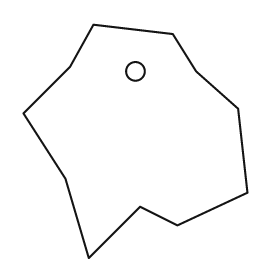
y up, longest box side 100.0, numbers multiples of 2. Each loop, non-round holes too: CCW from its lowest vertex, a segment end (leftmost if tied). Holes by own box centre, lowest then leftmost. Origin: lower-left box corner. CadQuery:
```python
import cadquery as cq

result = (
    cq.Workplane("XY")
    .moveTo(28.0, 0.0)
    .lineTo(50.0, 22.0)
    .lineTo(66.0, 14.0)
    .lineTo(96.0, 28.0)
    .lineTo(92.0, 64.0)
    .lineTo(74.0, 80.0)
    .lineTo(64.0, 96.0)
    .lineTo(30.0, 100.0)
    .lineTo(20.0, 82.0)
    .lineTo(0.0, 62.0)
    .lineTo(18.0, 34.0)
    .close()
    .moveTo(48.0, 80.0)
    .circle(4.0)
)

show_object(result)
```